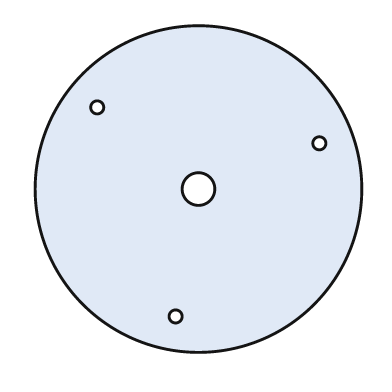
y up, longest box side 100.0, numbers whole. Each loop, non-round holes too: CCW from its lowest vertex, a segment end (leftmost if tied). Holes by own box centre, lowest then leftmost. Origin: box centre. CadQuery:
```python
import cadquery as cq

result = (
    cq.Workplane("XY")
    .moveTo(0.0, 0.0)
    .circle(50.0)
    .moveTo(-7.0, -39.0)
    .circle(2.0)
    .moveTo(0.0, 0.0)
    .circle(5.0)
    .moveTo(37.0, 14.0)
    .circle(2.0)
    .moveTo(-31.0, 25.0)
    .circle(2.0)
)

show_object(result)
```